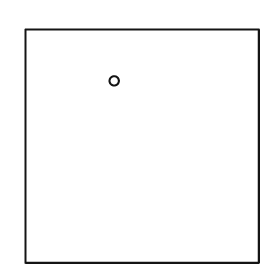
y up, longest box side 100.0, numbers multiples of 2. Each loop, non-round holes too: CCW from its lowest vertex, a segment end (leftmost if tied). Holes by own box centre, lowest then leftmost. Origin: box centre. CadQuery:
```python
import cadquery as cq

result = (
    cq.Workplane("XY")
    .moveTo(-50.0, -50.0)
    .lineTo(50.0, -50.0)
    .lineTo(50.0, 50.0)
    .lineTo(-50.0, 50.0)
    .close()
    .moveTo(-12.0, 28.0)
    .circle(2.0)
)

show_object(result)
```